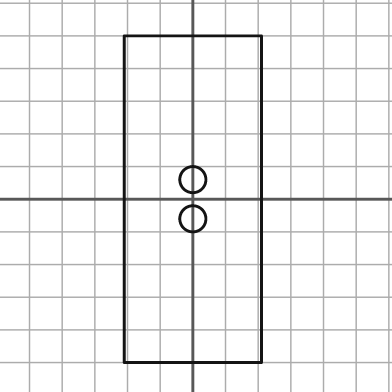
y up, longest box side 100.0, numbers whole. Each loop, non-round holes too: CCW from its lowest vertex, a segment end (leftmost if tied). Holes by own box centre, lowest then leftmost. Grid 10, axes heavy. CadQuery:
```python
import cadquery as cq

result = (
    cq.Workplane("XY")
    .moveTo(-21.0, -50.0)
    .lineTo(21.0, -50.0)
    .lineTo(21.0, 50.0)
    .lineTo(-21.0, 50.0)
    .close()
    .moveTo(0.0, -6.0)
    .circle(4.0)
    .moveTo(0.0, 6.0)
    .circle(4.0)
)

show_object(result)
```